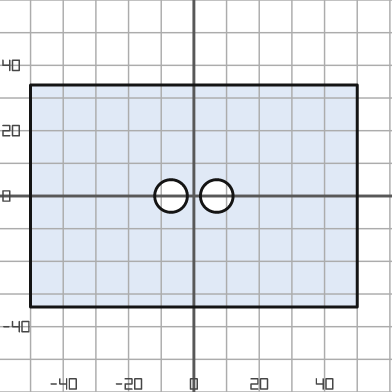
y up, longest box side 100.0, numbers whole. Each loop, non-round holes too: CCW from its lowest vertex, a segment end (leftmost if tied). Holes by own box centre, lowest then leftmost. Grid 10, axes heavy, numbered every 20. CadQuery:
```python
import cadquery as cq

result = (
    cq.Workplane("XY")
    .moveTo(-50.0, -34.0)
    .lineTo(50.0, -34.0)
    .lineTo(50.0, 34.0)
    .lineTo(-50.0, 34.0)
    .close()
    .moveTo(-7.0, 0.0)
    .circle(5.0)
    .moveTo(7.0, 0.0)
    .circle(5.0)
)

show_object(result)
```